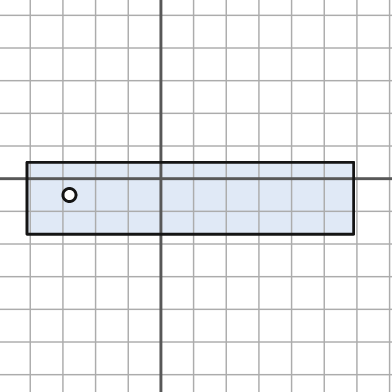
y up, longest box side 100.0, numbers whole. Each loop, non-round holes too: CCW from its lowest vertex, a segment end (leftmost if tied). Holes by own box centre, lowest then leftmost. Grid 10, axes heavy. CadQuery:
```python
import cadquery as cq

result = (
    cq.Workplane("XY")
    .moveTo(-41.0, -17.0)
    .lineTo(59.0, -17.0)
    .lineTo(59.0, 5.0)
    .lineTo(-41.0, 5.0)
    .close()
    .moveTo(-28.0, -5.0)
    .circle(2.0)
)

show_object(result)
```